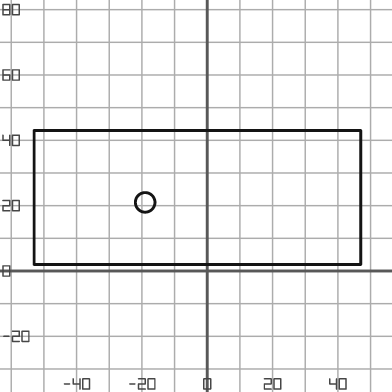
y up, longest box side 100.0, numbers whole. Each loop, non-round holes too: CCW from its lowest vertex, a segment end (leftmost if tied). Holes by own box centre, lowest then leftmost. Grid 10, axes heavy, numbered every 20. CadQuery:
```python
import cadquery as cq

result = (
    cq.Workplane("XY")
    .moveTo(-53.0, 2.0)
    .lineTo(47.0, 2.0)
    .lineTo(47.0, 43.0)
    .lineTo(-53.0, 43.0)
    .close()
    .moveTo(-19.0, 21.0)
    .circle(3.0)
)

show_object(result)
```